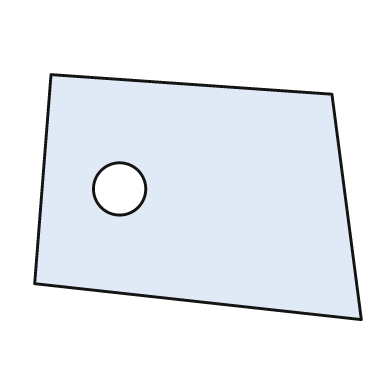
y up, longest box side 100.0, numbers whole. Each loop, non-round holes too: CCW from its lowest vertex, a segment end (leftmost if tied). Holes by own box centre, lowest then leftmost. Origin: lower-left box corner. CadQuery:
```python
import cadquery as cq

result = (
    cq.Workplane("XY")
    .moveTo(100.0, 0.0)
    .lineTo(91.0, 69.0)
    .lineTo(5.0, 75.0)
    .lineTo(0.0, 11.0)
    .close()
    .moveTo(26.0, 40.0)
    .circle(8.0)
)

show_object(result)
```